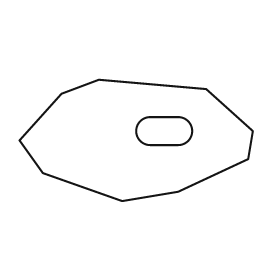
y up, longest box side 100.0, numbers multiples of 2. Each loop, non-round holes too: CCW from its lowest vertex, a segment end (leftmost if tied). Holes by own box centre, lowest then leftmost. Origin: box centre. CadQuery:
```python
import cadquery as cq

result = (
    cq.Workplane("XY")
    .moveTo(-6.0, -26.0)
    .lineTo(18.0, -22.0)
    .lineTo(48.0, -8.0)
    .lineTo(50.0, 4.0)
    .lineTo(30.0, 22.0)
    .lineTo(-16.0, 26.0)
    .lineTo(-32.0, 20.0)
    .lineTo(-50.0, 0.0)
    .lineTo(-40.0, -14.0)
    .close()
    .moveTo(6.0, -2.0)
    .lineTo(18.0, -2.0)
    .threePointArc((24.0, 4.0), (18.0, 10.0))
    .lineTo(6.0, 10.0)
    .threePointArc((0.0, 4.0), (6.0, -2.0))
    .close()
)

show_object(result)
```